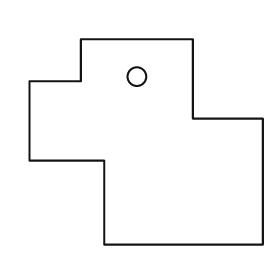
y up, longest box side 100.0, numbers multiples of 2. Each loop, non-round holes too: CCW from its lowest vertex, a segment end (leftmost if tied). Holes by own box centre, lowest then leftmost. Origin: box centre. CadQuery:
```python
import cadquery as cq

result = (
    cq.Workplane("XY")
    .moveTo(-18.0, -44.0)
    .lineTo(50.0, -44.0)
    .lineTo(50.0, 10.0)
    .lineTo(20.0, 10.0)
    .lineTo(20.0, 44.0)
    .lineTo(-28.0, 44.0)
    .lineTo(-28.0, 26.0)
    .lineTo(-50.0, 26.0)
    .lineTo(-50.0, -8.0)
    .lineTo(-18.0, -8.0)
    .close()
    .moveTo(-4.0, 28.0)
    .circle(4.0)
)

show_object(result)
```